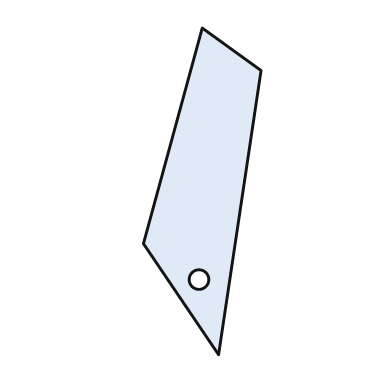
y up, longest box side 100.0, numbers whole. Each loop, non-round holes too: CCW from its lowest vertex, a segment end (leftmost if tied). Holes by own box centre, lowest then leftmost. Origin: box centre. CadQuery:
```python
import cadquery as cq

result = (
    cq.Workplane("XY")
    .moveTo(5.0, -50.0)
    .lineTo(18.0, 37.0)
    .lineTo(0.0, 50.0)
    .lineTo(-18.0, -16.0)
    .close()
    .moveTo(-1.0, -27.0)
    .circle(3.0)
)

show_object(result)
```